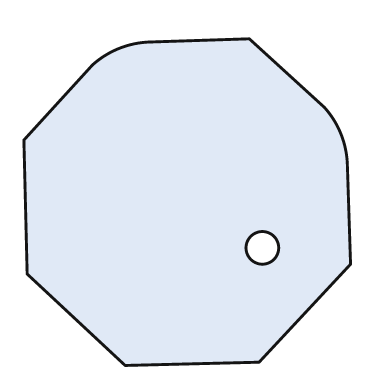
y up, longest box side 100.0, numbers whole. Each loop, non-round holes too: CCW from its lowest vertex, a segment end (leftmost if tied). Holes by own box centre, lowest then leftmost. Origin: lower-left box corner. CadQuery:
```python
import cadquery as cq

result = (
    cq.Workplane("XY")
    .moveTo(31.0, 0.0)
    .lineTo(72.0, 1.0)
    .lineTo(100.0, 31.0)
    .lineTo(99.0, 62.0)
    .threePointArc((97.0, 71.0), (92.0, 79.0))
    .lineTo(69.0, 100.0)
    .lineTo(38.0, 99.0)
    .threePointArc((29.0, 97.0), (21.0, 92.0))
    .lineTo(0.0, 69.0)
    .lineTo(1.0, 28.0)
    .close()
    .moveTo(73.0, 36.0)
    .circle(5.0)
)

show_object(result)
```